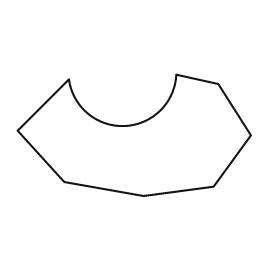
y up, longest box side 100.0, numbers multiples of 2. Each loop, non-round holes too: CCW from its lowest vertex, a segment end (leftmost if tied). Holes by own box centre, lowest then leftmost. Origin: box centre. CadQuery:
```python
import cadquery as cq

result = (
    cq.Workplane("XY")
    .moveTo(4.0, -26.0)
    .lineTo(34.0, -22.0)
    .lineTo(50.0, 0.0)
    .lineTo(36.0, 22.0)
    .lineTo(18.0, 26.0)
    .threePointArc((-4.0, 4.0), (-28.0, 24.0))
    .lineTo(-50.0, 2.0)
    .lineTo(-30.0, -20.0)
    .close()
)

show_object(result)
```